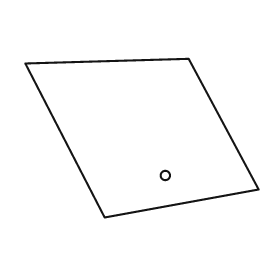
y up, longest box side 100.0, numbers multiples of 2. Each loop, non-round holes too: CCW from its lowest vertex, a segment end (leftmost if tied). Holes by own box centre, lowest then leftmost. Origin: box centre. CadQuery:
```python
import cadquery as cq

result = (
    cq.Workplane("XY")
    .moveTo(-16.0, -34.0)
    .lineTo(50.0, -22.0)
    .lineTo(20.0, 34.0)
    .lineTo(-50.0, 32.0)
    .close()
    .moveTo(10.0, -16.0)
    .circle(2.0)
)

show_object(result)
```